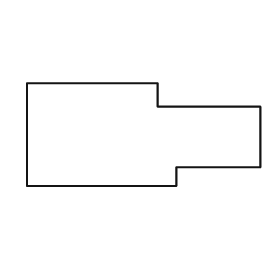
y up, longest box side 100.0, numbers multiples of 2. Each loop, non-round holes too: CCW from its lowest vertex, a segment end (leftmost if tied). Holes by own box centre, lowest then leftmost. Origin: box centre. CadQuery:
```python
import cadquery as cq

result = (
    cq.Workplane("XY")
    .moveTo(-50.0, -22.0)
    .lineTo(14.0, -22.0)
    .lineTo(14.0, -14.0)
    .lineTo(50.0, -14.0)
    .lineTo(50.0, 12.0)
    .lineTo(6.0, 12.0)
    .lineTo(6.0, 22.0)
    .lineTo(-50.0, 22.0)
    .close()
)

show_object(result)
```